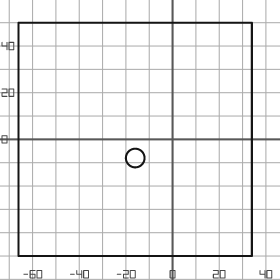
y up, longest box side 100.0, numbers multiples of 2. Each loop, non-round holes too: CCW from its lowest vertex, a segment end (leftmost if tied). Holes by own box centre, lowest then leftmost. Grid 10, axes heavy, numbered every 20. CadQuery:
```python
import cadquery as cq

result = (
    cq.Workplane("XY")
    .moveTo(-66.0, -50.0)
    .lineTo(34.0, -50.0)
    .lineTo(34.0, 50.0)
    .lineTo(-66.0, 50.0)
    .close()
    .moveTo(-16.0, -8.0)
    .circle(4.0)
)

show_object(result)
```